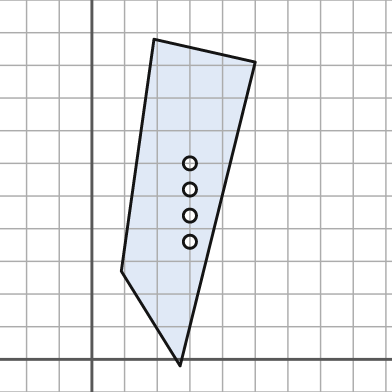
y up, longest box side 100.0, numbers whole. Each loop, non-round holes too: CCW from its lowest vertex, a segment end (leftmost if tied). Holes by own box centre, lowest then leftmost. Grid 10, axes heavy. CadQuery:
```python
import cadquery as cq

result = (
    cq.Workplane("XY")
    .moveTo(27.0, -2.0)
    .lineTo(50.0, 91.0)
    .lineTo(19.0, 98.0)
    .lineTo(9.0, 27.0)
    .close()
    .moveTo(30.0, 36.0)
    .circle(2.0)
    .moveTo(30.0, 44.0)
    .circle(2.0)
    .moveTo(30.0, 52.0)
    .circle(2.0)
    .moveTo(30.0, 60.0)
    .circle(2.0)
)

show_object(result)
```